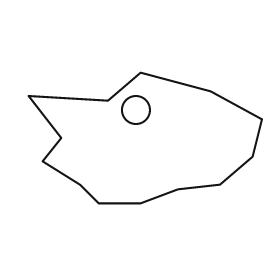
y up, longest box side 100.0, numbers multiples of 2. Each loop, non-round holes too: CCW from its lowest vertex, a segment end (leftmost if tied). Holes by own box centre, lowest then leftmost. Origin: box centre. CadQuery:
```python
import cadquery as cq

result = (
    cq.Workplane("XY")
    .moveTo(-20.0, -28.0)
    .lineTo(-2.0, -28.0)
    .lineTo(14.0, -22.0)
    .lineTo(32.0, -20.0)
    .lineTo(46.0, -8.0)
    .lineTo(50.0, 8.0)
    .lineTo(28.0, 20.0)
    .lineTo(-2.0, 28.0)
    .lineTo(-16.0, 16.0)
    .lineTo(-50.0, 18.0)
    .lineTo(-36.0, 0.0)
    .lineTo(-44.0, -10.0)
    .lineTo(-28.0, -20.0)
    .close()
    .moveTo(-4.0, 12.0)
    .circle(6.0)
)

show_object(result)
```